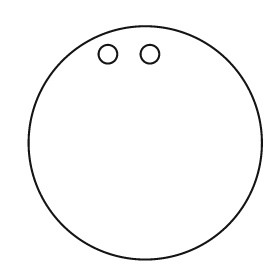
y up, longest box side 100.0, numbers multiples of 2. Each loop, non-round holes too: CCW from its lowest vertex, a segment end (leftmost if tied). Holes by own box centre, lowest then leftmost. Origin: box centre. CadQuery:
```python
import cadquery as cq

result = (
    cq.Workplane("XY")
    .moveTo(0.0, 0.0)
    .circle(50.0)
    .moveTo(-16.0, 38.0)
    .circle(4.0)
    .moveTo(2.0, 38.0)
    .circle(4.0)
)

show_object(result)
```